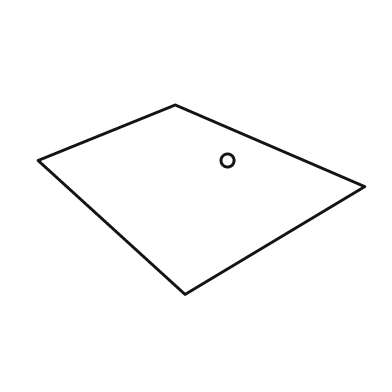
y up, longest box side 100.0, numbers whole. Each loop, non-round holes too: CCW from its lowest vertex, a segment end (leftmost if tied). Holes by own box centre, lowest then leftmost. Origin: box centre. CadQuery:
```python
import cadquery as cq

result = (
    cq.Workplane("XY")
    .moveTo(-5.0, -29.0)
    .lineTo(50.0, 4.0)
    .lineTo(-8.0, 29.0)
    .lineTo(-50.0, 12.0)
    .close()
    .moveTo(8.0, 12.0)
    .circle(2.0)
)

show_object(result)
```